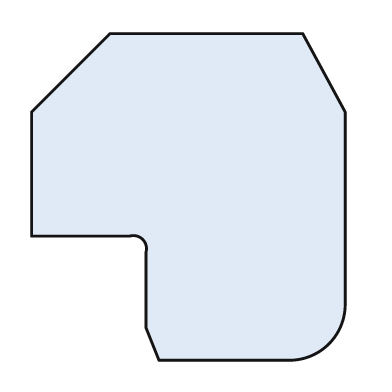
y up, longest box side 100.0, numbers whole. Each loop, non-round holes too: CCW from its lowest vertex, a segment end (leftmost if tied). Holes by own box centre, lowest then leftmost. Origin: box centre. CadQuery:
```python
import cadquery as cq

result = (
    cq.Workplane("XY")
    .moveTo(-9.0, -50.0)
    .lineTo(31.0, -50.0)
    .threePointArc((43.0, -45.0), (48.0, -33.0))
    .lineTo(48.0, 26.0)
    .lineTo(35.0, 50.0)
    .lineTo(-24.0, 50.0)
    .lineTo(-48.0, 26.0)
    .lineTo(-48.0, -12.0)
    .lineTo(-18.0, -12.0)
    .threePointArc((-14.0, -13.0), (-13.0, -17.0))
    .lineTo(-13.0, -40.0)
    .close()
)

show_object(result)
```